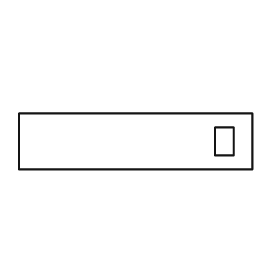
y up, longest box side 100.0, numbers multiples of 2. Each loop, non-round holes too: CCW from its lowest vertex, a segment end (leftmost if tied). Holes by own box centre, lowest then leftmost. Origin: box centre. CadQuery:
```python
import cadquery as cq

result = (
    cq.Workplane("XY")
    .moveTo(-50.0, -12.0)
    .lineTo(50.0, -12.0)
    .lineTo(50.0, 12.0)
    .lineTo(-50.0, 12.0)
    .close()
    .moveTo(34.0, -6.0)
    .lineTo(42.0, -6.0)
    .lineTo(42.0, 6.0)
    .lineTo(34.0, 6.0)
    .close()
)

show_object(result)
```